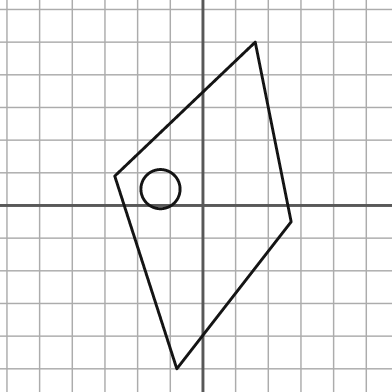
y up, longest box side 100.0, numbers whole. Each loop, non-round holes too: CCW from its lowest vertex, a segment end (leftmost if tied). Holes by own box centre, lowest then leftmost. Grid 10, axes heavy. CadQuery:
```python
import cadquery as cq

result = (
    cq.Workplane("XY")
    .moveTo(-8.0, -50.0)
    .lineTo(27.0, -5.0)
    .lineTo(16.0, 50.0)
    .lineTo(-27.0, 9.0)
    .close()
    .moveTo(-13.0, 5.0)
    .circle(6.0)
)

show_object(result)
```